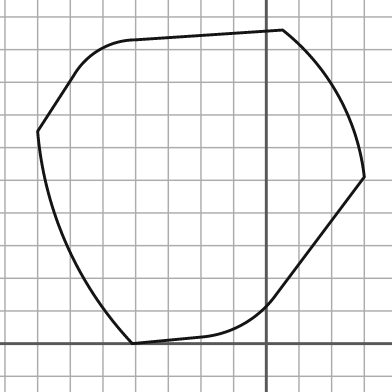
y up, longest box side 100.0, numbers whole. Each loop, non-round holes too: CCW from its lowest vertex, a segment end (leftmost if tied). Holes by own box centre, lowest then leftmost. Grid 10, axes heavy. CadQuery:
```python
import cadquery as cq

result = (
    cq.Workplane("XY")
    .moveTo(-41.0, 0.0)
    .lineTo(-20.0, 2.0)
    .threePointArc((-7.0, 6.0), (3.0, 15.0))
    .lineTo(30.0, 51.0)
    .threePointArc((22.0, 76.0), (5.0, 96.0))
    .lineTo(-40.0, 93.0)
    .threePointArc((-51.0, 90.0), (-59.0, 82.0))
    .lineTo(-70.0, 65.0)
    .threePointArc((-61.0, 30.0), (-41.0, 0.0))
    .close()
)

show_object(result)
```